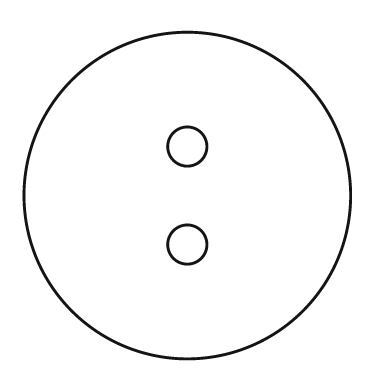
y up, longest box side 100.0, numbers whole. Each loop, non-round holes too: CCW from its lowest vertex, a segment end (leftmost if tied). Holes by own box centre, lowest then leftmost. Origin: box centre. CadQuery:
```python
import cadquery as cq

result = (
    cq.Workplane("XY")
    .moveTo(0.0, 0.0)
    .circle(50.0)
    .moveTo(0.0, -15.0)
    .circle(6.0)
    .moveTo(0.0, 15.0)
    .circle(6.0)
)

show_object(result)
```